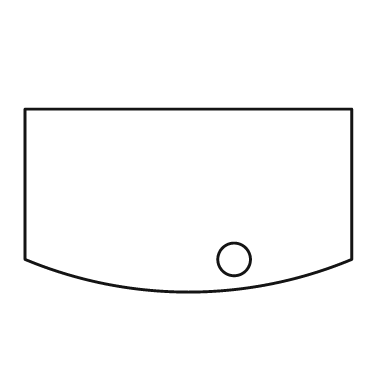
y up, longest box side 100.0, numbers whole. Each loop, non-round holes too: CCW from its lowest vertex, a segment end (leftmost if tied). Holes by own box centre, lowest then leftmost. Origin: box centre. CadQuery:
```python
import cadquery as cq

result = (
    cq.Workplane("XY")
    .moveTo(-50.0, -18.0)
    .threePointArc((0.0, -28.0), (50.0, -18.0))
    .lineTo(50.0, 28.0)
    .lineTo(-50.0, 28.0)
    .close()
    .moveTo(14.0, -18.0)
    .circle(5.0)
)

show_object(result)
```